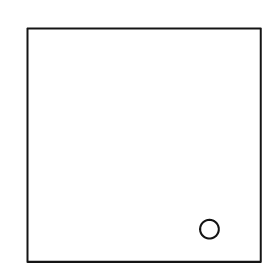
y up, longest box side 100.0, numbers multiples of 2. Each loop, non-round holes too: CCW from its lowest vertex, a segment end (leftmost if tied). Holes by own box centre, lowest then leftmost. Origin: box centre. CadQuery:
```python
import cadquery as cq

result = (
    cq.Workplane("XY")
    .moveTo(-50.0, -50.0)
    .lineTo(50.0, -50.0)
    .lineTo(50.0, 50.0)
    .lineTo(-50.0, 50.0)
    .close()
    .moveTo(28.0, -36.0)
    .circle(4.0)
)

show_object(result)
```